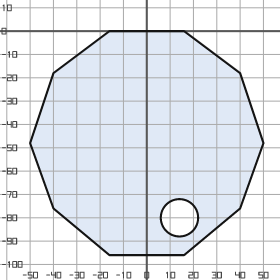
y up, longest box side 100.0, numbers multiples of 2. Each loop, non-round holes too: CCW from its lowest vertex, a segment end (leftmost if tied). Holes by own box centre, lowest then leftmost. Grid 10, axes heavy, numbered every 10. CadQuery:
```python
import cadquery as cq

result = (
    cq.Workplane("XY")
    .moveTo(-16.0, -96.0)
    .lineTo(16.0, -96.0)
    .lineTo(40.0, -76.0)
    .lineTo(50.0, -48.0)
    .lineTo(40.0, -18.0)
    .lineTo(16.0, 0.0)
    .lineTo(-16.0, 0.0)
    .lineTo(-40.0, -18.0)
    .lineTo(-50.0, -48.0)
    .lineTo(-40.0, -76.0)
    .close()
    .moveTo(14.0, -80.0)
    .circle(8.0)
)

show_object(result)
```